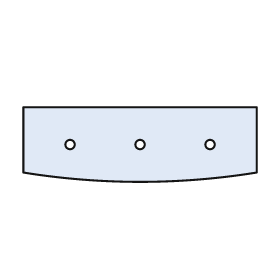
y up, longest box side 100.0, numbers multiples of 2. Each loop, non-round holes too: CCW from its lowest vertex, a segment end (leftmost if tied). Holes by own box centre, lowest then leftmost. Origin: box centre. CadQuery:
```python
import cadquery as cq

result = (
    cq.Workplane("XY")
    .moveTo(-50.0, -12.0)
    .threePointArc((0.0, -16.0), (50.0, -12.0))
    .lineTo(50.0, 16.0)
    .lineTo(-50.0, 16.0)
    .close()
    .moveTo(-30.0, 0.0)
    .circle(2.0)
    .moveTo(0.0, 0.0)
    .circle(2.0)
    .moveTo(30.0, 0.0)
    .circle(2.0)
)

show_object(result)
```